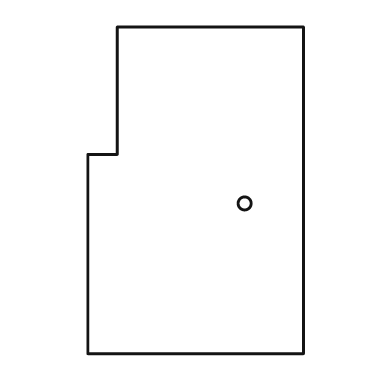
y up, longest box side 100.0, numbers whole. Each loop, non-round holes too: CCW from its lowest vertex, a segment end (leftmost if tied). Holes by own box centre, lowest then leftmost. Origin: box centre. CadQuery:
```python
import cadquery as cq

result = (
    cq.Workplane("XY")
    .moveTo(-33.0, -50.0)
    .lineTo(33.0, -50.0)
    .lineTo(33.0, 50.0)
    .lineTo(-24.0, 50.0)
    .lineTo(-24.0, 11.0)
    .lineTo(-33.0, 11.0)
    .close()
    .moveTo(15.0, -4.0)
    .circle(2.0)
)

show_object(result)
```